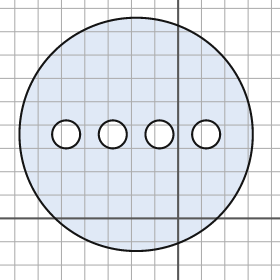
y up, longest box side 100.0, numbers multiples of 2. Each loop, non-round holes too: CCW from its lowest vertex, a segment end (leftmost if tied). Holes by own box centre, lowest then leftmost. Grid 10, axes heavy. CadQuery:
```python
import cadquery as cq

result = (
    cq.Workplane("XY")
    .moveTo(-18.0, 36.0)
    .circle(50.0)
    .moveTo(-48.0, 36.0)
    .circle(6.0)
    .moveTo(-28.0, 36.0)
    .circle(6.0)
    .moveTo(-8.0, 36.0)
    .circle(6.0)
    .moveTo(12.0, 36.0)
    .circle(6.0)
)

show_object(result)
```